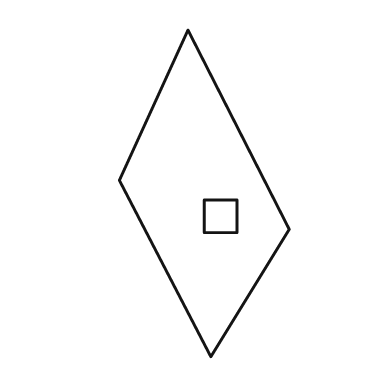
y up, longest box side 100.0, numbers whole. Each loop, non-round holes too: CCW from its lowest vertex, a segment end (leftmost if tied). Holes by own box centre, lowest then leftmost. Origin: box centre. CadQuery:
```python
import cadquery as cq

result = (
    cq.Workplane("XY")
    .moveTo(2.0, -50.0)
    .lineTo(26.0, -11.0)
    .lineTo(-5.0, 50.0)
    .lineTo(-26.0, 4.0)
    .close()
    .moveTo(0.0, -12.0)
    .lineTo(10.0, -12.0)
    .lineTo(10.0, -2.0)
    .lineTo(0.0, -2.0)
    .close()
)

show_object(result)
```